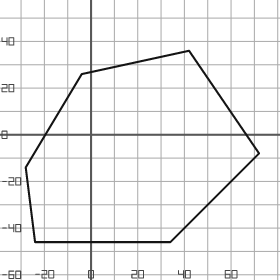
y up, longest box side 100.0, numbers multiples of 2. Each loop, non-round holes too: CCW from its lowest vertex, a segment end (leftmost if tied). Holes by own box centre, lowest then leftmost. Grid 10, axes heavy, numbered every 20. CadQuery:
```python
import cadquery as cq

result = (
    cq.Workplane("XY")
    .moveTo(-24.0, -46.0)
    .lineTo(34.0, -46.0)
    .lineTo(72.0, -8.0)
    .lineTo(42.0, 36.0)
    .lineTo(-4.0, 26.0)
    .lineTo(-28.0, -14.0)
    .close()
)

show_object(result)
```